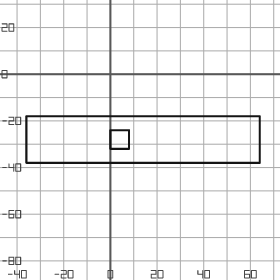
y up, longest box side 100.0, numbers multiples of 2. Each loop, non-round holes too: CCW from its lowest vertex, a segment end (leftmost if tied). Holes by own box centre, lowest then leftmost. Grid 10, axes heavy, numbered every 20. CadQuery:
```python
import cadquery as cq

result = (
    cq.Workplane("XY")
    .moveTo(-36.0, -38.0)
    .lineTo(64.0, -38.0)
    .lineTo(64.0, -18.0)
    .lineTo(-36.0, -18.0)
    .close()
    .moveTo(0.0, -32.0)
    .lineTo(8.0, -32.0)
    .lineTo(8.0, -24.0)
    .lineTo(0.0, -24.0)
    .close()
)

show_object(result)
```